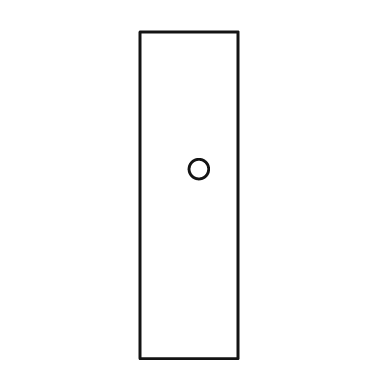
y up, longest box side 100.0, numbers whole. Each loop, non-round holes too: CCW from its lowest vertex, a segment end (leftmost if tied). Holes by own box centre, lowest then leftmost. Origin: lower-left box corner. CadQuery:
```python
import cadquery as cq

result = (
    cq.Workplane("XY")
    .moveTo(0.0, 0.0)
    .lineTo(30.0, 0.0)
    .lineTo(30.0, 100.0)
    .lineTo(0.0, 100.0)
    .close()
    .moveTo(18.0, 58.0)
    .circle(3.0)
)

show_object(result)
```